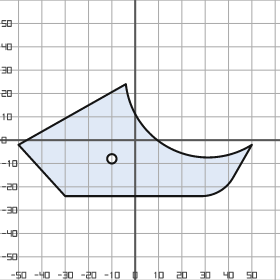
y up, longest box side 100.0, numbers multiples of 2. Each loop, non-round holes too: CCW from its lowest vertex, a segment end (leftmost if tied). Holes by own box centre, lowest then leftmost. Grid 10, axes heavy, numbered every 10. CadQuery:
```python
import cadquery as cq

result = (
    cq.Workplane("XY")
    .moveTo(-30.0, -24.0)
    .lineTo(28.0, -24.0)
    .threePointArc((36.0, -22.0), (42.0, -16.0))
    .lineTo(50.0, -2.0)
    .threePointArc((16.0, -4.0), (-4.0, 24.0))
    .lineTo(-50.0, -2.0)
    .close()
    .moveTo(-10.0, -8.0)
    .circle(2.0)
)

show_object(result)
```